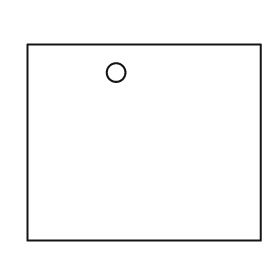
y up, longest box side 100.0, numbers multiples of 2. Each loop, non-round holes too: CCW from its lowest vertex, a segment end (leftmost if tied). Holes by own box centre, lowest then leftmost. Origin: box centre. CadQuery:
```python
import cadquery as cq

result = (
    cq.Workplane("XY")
    .moveTo(-50.0, -42.0)
    .lineTo(50.0, -42.0)
    .lineTo(50.0, 42.0)
    .lineTo(-50.0, 42.0)
    .close()
    .moveTo(-12.0, 30.0)
    .circle(4.0)
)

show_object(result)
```